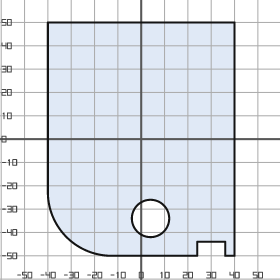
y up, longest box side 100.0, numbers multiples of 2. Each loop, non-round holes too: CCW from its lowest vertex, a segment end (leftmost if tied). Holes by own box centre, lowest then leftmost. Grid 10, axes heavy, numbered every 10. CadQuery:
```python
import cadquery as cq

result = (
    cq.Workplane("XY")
    .moveTo(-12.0, -50.0)
    .lineTo(24.0, -50.0)
    .lineTo(24.0, -44.0)
    .lineTo(36.0, -44.0)
    .lineTo(36.0, -50.0)
    .lineTo(40.0, -50.0)
    .lineTo(40.0, 50.0)
    .lineTo(-40.0, 50.0)
    .lineTo(-40.0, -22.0)
    .threePointArc((-32.0, -42.0), (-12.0, -50.0))
    .close()
    .moveTo(4.0, -34.0)
    .circle(8.0)
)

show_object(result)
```